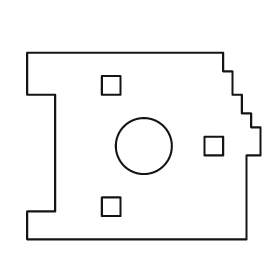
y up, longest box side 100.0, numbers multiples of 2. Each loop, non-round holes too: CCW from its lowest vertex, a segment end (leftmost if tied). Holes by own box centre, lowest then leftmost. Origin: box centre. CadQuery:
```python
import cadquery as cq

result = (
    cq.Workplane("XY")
    .moveTo(-50.0, -40.0)
    .lineTo(44.0, -40.0)
    .lineTo(44.0, -4.0)
    .lineTo(50.0, -4.0)
    .lineTo(50.0, 8.0)
    .lineTo(46.0, 8.0)
    .lineTo(46.0, 14.0)
    .lineTo(42.0, 14.0)
    .lineTo(42.0, 22.0)
    .lineTo(38.0, 22.0)
    .lineTo(38.0, 32.0)
    .lineTo(34.0, 32.0)
    .lineTo(34.0, 40.0)
    .lineTo(-50.0, 40.0)
    .lineTo(-50.0, 22.0)
    .lineTo(-38.0, 22.0)
    .lineTo(-38.0, -28.0)
    .lineTo(-50.0, -28.0)
    .close()
    .moveTo(-18.0, -30.0)
    .lineTo(-10.0, -30.0)
    .lineTo(-10.0, -22.0)
    .lineTo(-18.0, -22.0)
    .close()
    .moveTo(0.0, 0.0)
    .circle(12.0)
    .moveTo(26.0, -4.0)
    .lineTo(34.0, -4.0)
    .lineTo(34.0, 4.0)
    .lineTo(26.0, 4.0)
    .close()
    .moveTo(-18.0, 22.0)
    .lineTo(-10.0, 22.0)
    .lineTo(-10.0, 30.0)
    .lineTo(-18.0, 30.0)
    .close()
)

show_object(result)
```